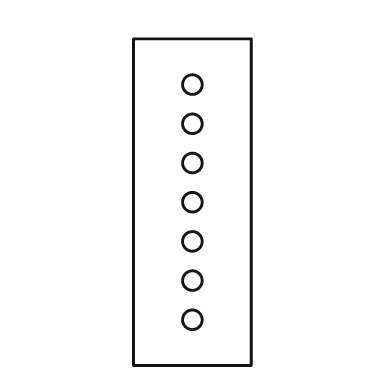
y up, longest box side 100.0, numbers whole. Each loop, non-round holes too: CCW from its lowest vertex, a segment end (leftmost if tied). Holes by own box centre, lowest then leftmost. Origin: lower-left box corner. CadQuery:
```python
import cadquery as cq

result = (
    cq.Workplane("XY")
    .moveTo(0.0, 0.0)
    .lineTo(36.0, 0.0)
    .lineTo(36.0, 100.0)
    .lineTo(0.0, 100.0)
    .close()
    .moveTo(18.0, 14.0)
    .circle(3.0)
    .moveTo(18.0, 26.0)
    .circle(3.0)
    .moveTo(18.0, 38.0)
    .circle(3.0)
    .moveTo(18.0, 50.0)
    .circle(3.0)
    .moveTo(18.0, 62.0)
    .circle(3.0)
    .moveTo(18.0, 74.0)
    .circle(3.0)
    .moveTo(18.0, 86.0)
    .circle(3.0)
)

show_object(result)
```